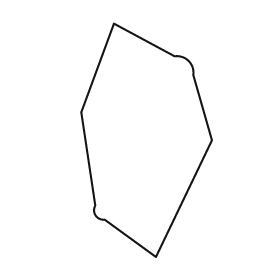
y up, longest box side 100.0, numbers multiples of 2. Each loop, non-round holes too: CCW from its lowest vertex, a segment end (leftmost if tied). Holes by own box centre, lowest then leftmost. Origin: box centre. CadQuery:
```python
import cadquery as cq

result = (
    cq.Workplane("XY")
    .moveTo(4.0, -50.0)
    .lineTo(28.0, 0.0)
    .lineTo(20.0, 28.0)
    .threePointArc((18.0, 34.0), (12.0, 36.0))
    .lineTo(-14.0, 50.0)
    .lineTo(-28.0, 12.0)
    .lineTo(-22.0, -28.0)
    .threePointArc((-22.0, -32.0), (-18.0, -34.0))
    .close()
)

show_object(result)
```